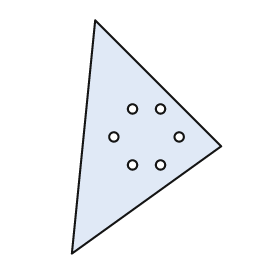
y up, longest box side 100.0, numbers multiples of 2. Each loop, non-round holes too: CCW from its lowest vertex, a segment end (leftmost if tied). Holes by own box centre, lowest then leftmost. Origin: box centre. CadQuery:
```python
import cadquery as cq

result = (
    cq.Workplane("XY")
    .moveTo(-32.0, -50.0)
    .lineTo(32.0, -4.0)
    .lineTo(-22.0, 50.0)
    .close()
    .moveTo(-6.0, -12.0)
    .circle(2.0)
    .moveTo(6.0, -12.0)
    .circle(2.0)
    .moveTo(-14.0, 0.0)
    .circle(2.0)
    .moveTo(14.0, 0.0)
    .circle(2.0)
    .moveTo(-6.0, 12.0)
    .circle(2.0)
    .moveTo(6.0, 12.0)
    .circle(2.0)
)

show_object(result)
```